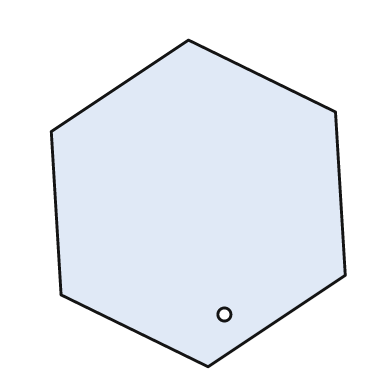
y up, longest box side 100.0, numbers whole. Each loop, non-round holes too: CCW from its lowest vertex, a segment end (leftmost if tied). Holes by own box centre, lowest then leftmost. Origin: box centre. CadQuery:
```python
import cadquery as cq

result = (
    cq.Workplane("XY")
    .moveTo(3.0, -50.0)
    .lineTo(45.0, -22.0)
    .lineTo(42.0, 28.0)
    .lineTo(-3.0, 50.0)
    .lineTo(-45.0, 22.0)
    .lineTo(-42.0, -28.0)
    .close()
    .moveTo(8.0, -34.0)
    .circle(2.0)
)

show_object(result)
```